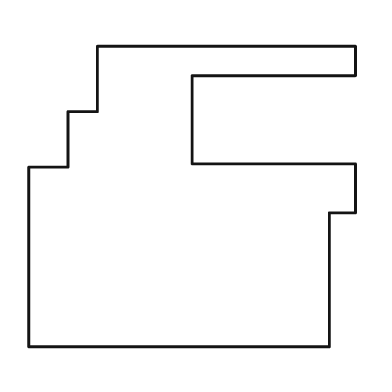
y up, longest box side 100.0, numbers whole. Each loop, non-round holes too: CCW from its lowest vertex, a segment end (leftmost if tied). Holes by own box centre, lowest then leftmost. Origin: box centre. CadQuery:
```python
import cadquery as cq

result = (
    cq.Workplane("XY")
    .moveTo(-50.0, -46.0)
    .lineTo(42.0, -46.0)
    .lineTo(42.0, -5.0)
    .lineTo(50.0, -5.0)
    .lineTo(50.0, 10.0)
    .lineTo(0.0, 10.0)
    .lineTo(0.0, 37.0)
    .lineTo(50.0, 37.0)
    .lineTo(50.0, 46.0)
    .lineTo(-29.0, 46.0)
    .lineTo(-29.0, 26.0)
    .lineTo(-38.0, 26.0)
    .lineTo(-38.0, 9.0)
    .lineTo(-50.0, 9.0)
    .close()
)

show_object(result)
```